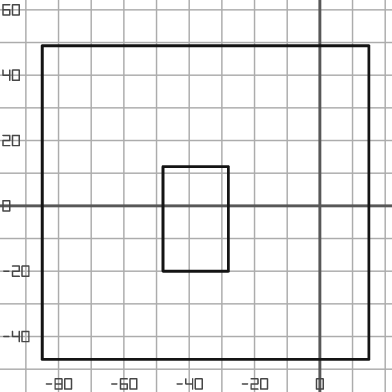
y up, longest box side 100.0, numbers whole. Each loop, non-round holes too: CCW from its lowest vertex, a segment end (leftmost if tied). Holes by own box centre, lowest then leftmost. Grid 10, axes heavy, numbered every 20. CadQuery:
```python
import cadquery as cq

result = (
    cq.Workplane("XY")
    .moveTo(-85.0, -47.0)
    .lineTo(15.0, -47.0)
    .lineTo(15.0, 49.0)
    .lineTo(-85.0, 49.0)
    .close()
    .moveTo(-48.0, -20.0)
    .lineTo(-28.0, -20.0)
    .lineTo(-28.0, 12.0)
    .lineTo(-48.0, 12.0)
    .close()
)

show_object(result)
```